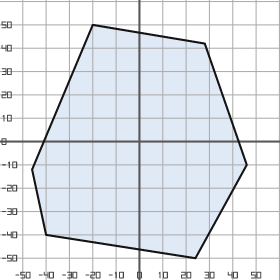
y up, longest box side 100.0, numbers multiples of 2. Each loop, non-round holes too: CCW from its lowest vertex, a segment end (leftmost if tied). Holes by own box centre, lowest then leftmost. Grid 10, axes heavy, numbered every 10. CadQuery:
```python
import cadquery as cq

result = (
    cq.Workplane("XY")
    .moveTo(24.0, -50.0)
    .lineTo(46.0, -10.0)
    .lineTo(28.0, 42.0)
    .lineTo(-20.0, 50.0)
    .lineTo(-46.0, -12.0)
    .lineTo(-40.0, -40.0)
    .close()
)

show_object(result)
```